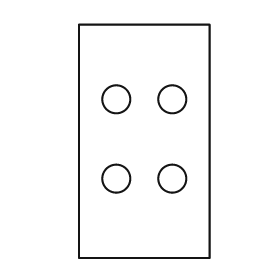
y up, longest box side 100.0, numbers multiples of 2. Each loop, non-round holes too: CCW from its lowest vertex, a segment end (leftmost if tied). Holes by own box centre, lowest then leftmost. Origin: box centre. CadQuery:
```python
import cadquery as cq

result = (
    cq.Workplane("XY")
    .moveTo(-28.0, -50.0)
    .lineTo(28.0, -50.0)
    .lineTo(28.0, 50.0)
    .lineTo(-28.0, 50.0)
    .close()
    .moveTo(-12.0, -16.0)
    .circle(6.0)
    .moveTo(12.0, -16.0)
    .circle(6.0)
    .moveTo(-12.0, 18.0)
    .circle(6.0)
    .moveTo(12.0, 18.0)
    .circle(6.0)
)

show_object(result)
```